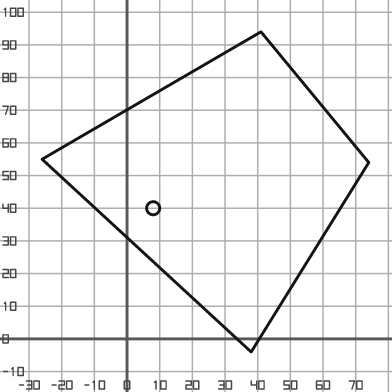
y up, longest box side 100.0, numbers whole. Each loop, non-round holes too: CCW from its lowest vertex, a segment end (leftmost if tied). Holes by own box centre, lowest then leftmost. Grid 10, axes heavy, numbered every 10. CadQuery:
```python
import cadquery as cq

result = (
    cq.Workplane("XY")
    .moveTo(38.0, -4.0)
    .lineTo(74.0, 54.0)
    .lineTo(41.0, 94.0)
    .lineTo(-26.0, 55.0)
    .close()
    .moveTo(8.0, 40.0)
    .circle(2.0)
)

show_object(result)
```